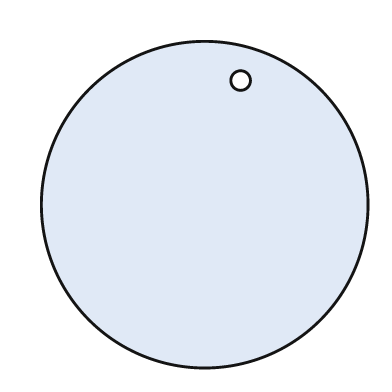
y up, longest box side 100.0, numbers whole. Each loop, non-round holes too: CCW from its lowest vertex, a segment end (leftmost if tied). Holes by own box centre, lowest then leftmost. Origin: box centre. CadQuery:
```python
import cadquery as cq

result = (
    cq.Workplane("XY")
    .moveTo(0.0, 0.0)
    .circle(50.0)
    .moveTo(11.0, 38.0)
    .circle(3.0)
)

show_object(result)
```